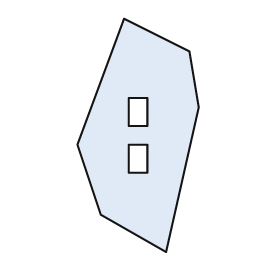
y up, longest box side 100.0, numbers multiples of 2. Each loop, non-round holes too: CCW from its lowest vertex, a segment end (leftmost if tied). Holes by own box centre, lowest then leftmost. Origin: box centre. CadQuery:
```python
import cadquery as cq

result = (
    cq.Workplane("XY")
    .moveTo(12.0, -50.0)
    .lineTo(26.0, 12.0)
    .lineTo(22.0, 36.0)
    .lineTo(-6.0, 50.0)
    .lineTo(-26.0, -4.0)
    .lineTo(-16.0, -34.0)
    .close()
    .moveTo(-4.0, -16.0)
    .lineTo(4.0, -16.0)
    .lineTo(4.0, -4.0)
    .lineTo(-4.0, -4.0)
    .close()
    .moveTo(-4.0, 4.0)
    .lineTo(4.0, 4.0)
    .lineTo(4.0, 16.0)
    .lineTo(-4.0, 16.0)
    .close()
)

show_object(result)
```